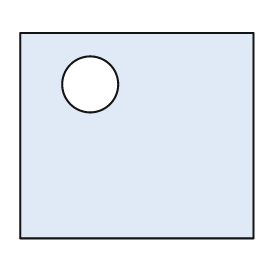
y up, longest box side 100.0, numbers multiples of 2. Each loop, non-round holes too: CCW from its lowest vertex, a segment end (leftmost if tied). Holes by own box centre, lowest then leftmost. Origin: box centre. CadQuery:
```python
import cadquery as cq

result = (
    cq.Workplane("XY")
    .moveTo(-50.0, -44.0)
    .lineTo(50.0, -44.0)
    .lineTo(50.0, 44.0)
    .lineTo(-50.0, 44.0)
    .close()
    .moveTo(-20.0, 22.0)
    .circle(12.0)
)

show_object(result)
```